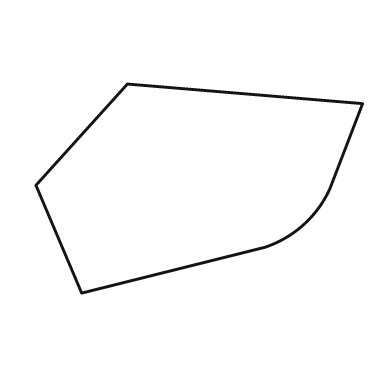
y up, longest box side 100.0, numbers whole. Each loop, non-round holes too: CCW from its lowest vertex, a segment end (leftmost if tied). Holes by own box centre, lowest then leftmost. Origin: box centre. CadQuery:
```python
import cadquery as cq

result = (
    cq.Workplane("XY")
    .moveTo(-36.0, -32.0)
    .lineTo(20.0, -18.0)
    .threePointArc((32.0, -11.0), (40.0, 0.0))
    .lineTo(50.0, 26.0)
    .lineTo(-22.0, 32.0)
    .lineTo(-50.0, 1.0)
    .close()
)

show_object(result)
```